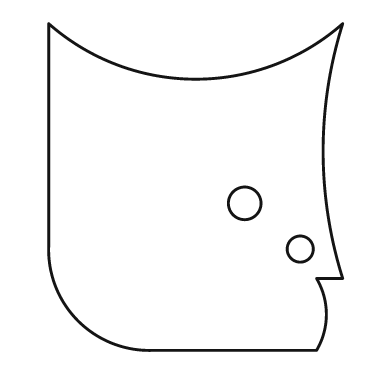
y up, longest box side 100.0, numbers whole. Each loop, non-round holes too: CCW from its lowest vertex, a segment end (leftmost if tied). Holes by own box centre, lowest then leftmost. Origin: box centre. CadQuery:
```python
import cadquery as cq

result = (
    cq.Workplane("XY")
    .moveTo(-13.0, -50.0)
    .lineTo(37.0, -50.0)
    .threePointArc((40.0, -39.0), (37.0, -28.0))
    .lineTo(45.0, -28.0)
    .threePointArc((39.0, 11.0), (45.0, 50.0))
    .threePointArc((0.0, 33.0), (-45.0, 50.0))
    .lineTo(-45.0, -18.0)
    .threePointArc((-36.0, -41.0), (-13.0, -50.0))
    .close()
    .moveTo(32.0, -19.0)
    .circle(4.0)
    .moveTo(15.0, -5.0)
    .circle(5.0)
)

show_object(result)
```